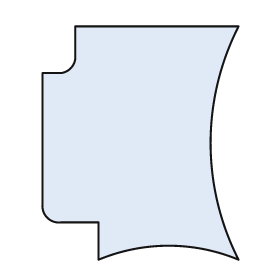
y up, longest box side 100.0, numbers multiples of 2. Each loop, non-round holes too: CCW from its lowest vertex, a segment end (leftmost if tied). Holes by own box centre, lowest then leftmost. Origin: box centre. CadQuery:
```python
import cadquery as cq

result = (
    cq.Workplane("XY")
    .moveTo(-18.0, -50.0)
    .threePointArc((12.0, -44.0), (42.0, -50.0))
    .threePointArc((30.0, 0.0), (42.0, 50.0))
    .lineTo(-28.0, 50.0)
    .lineTo(-28.0, 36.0)
    .threePointArc((-30.0, 32.0), (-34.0, 30.0))
    .lineTo(-42.0, 30.0)
    .lineTo(-42.0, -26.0)
    .threePointArc((-40.0, -32.0), (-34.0, -34.0))
    .lineTo(-18.0, -34.0)
    .close()
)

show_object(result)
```